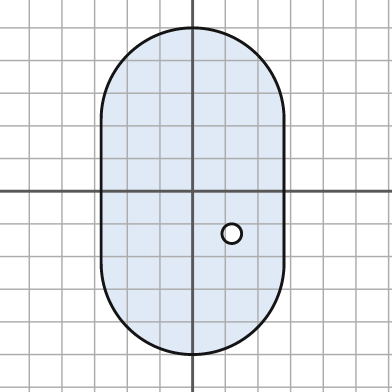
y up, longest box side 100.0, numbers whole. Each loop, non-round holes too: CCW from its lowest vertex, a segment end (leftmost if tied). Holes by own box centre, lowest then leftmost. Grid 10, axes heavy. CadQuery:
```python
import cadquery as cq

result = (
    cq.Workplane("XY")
    .moveTo(-28.0, -22.0)
    .threePointArc((0.0, -50.0), (28.0, -22.0))
    .lineTo(28.0, 22.0)
    .threePointArc((0.0, 50.0), (-28.0, 22.0))
    .close()
    .moveTo(12.0, -13.0)
    .circle(3.0)
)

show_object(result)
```